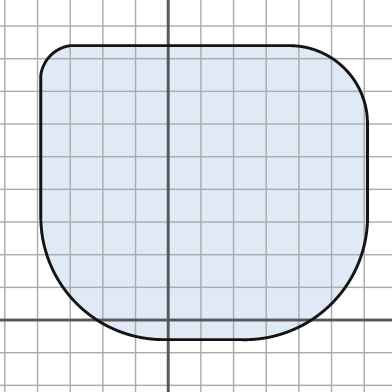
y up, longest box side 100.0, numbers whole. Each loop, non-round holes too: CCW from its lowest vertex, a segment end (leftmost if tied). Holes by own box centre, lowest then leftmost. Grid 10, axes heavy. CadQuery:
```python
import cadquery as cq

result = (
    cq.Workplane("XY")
    .moveTo(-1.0, -6.0)
    .lineTo(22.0, -6.0)
    .threePointArc((50.0, 5.0), (61.0, 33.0))
    .lineTo(61.0, 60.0)
    .threePointArc((54.0, 77.0), (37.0, 84.0))
    .lineTo(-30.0, 84.0)
    .threePointArc((-36.0, 81.0), (-39.0, 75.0))
    .lineTo(-39.0, 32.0)
    .threePointArc((-28.0, 5.0), (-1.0, -6.0))
    .close()
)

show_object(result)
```